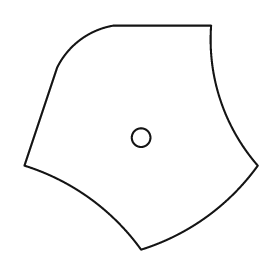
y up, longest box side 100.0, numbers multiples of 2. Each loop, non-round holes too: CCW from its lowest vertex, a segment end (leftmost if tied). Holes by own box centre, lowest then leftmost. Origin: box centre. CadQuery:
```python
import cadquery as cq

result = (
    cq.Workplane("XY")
    .moveTo(0.0, -48.0)
    .threePointArc((28.0, -34.0), (50.0, -12.0))
    .threePointArc((34.0, 16.0), (30.0, 48.0))
    .lineTo(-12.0, 48.0)
    .threePointArc((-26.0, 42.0), (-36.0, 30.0))
    .lineTo(-50.0, -12.0)
    .threePointArc((-22.0, -26.0), (0.0, -48.0))
    .close()
    .moveTo(0.0, 0.0)
    .circle(4.0)
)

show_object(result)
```